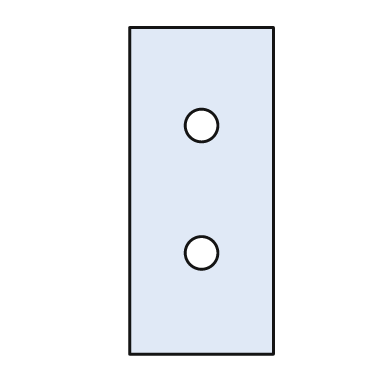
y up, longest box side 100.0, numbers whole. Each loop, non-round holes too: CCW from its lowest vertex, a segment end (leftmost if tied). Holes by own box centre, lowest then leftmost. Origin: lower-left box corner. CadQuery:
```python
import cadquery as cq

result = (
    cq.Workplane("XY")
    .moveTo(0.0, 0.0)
    .lineTo(44.0, 0.0)
    .lineTo(44.0, 100.0)
    .lineTo(0.0, 100.0)
    .close()
    .moveTo(22.0, 31.0)
    .circle(5.0)
    .moveTo(22.0, 70.0)
    .circle(5.0)
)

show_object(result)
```